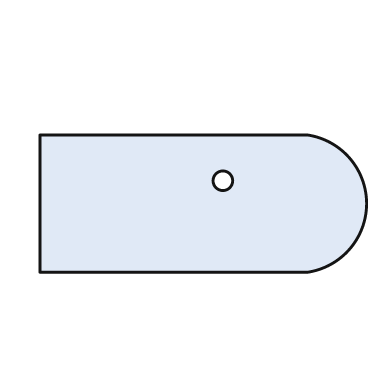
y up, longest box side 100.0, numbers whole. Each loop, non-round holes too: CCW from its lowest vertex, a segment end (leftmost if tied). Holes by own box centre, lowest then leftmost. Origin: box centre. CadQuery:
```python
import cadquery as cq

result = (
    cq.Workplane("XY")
    .moveTo(-50.0, -21.0)
    .lineTo(32.0, -21.0)
    .threePointArc((50.0, 0.0), (32.0, 21.0))
    .lineTo(-50.0, 21.0)
    .close()
    .moveTo(6.0, 7.0)
    .circle(3.0)
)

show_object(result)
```